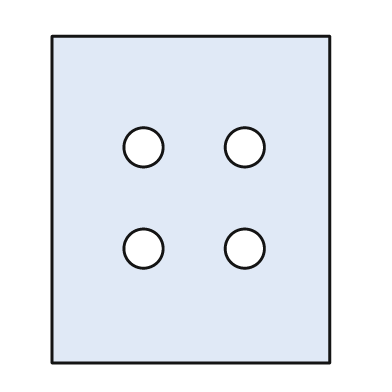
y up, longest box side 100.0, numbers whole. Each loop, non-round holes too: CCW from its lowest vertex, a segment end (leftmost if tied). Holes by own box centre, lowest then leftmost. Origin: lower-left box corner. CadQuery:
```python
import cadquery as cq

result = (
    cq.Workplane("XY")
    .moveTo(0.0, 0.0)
    .lineTo(85.0, 0.0)
    .lineTo(85.0, 100.0)
    .lineTo(0.0, 100.0)
    .close()
    .moveTo(28.0, 35.0)
    .circle(6.0)
    .moveTo(59.0, 35.0)
    .circle(6.0)
    .moveTo(28.0, 66.0)
    .circle(6.0)
    .moveTo(59.0, 66.0)
    .circle(6.0)
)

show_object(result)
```